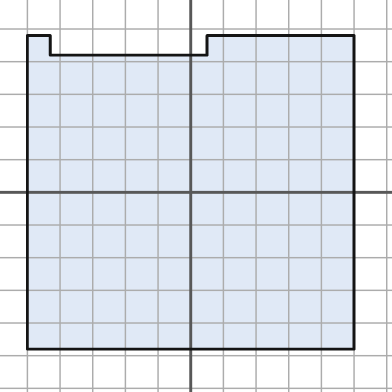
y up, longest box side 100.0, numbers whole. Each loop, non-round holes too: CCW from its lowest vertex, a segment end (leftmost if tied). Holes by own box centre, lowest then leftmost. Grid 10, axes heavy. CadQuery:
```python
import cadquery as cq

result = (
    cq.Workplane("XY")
    .moveTo(-50.0, -48.0)
    .lineTo(50.0, -48.0)
    .lineTo(50.0, 48.0)
    .lineTo(5.0, 48.0)
    .lineTo(5.0, 42.0)
    .lineTo(-43.0, 42.0)
    .lineTo(-43.0, 48.0)
    .lineTo(-50.0, 48.0)
    .close()
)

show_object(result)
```